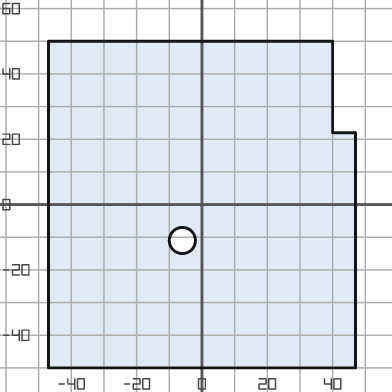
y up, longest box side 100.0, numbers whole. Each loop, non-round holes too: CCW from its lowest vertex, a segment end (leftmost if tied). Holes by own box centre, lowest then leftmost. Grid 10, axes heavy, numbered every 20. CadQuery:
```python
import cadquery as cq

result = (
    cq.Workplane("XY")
    .moveTo(-47.0, -50.0)
    .lineTo(47.0, -50.0)
    .lineTo(47.0, 22.0)
    .lineTo(40.0, 22.0)
    .lineTo(40.0, 50.0)
    .lineTo(-47.0, 50.0)
    .close()
    .moveTo(-6.0, -11.0)
    .circle(4.0)
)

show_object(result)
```